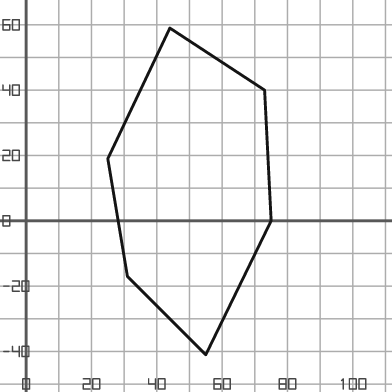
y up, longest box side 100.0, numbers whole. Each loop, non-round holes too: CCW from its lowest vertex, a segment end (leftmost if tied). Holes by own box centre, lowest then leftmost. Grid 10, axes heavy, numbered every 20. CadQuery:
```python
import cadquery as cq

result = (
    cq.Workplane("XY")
    .moveTo(55.0, -41.0)
    .lineTo(75.0, 0.0)
    .lineTo(73.0, 40.0)
    .lineTo(44.0, 59.0)
    .lineTo(25.0, 19.0)
    .lineTo(31.0, -17.0)
    .close()
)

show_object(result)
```